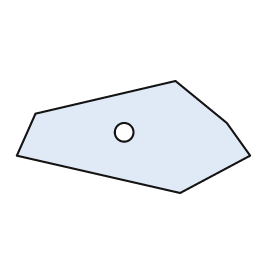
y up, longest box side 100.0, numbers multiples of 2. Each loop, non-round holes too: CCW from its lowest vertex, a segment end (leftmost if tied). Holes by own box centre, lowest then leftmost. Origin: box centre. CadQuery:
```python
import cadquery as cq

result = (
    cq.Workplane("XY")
    .moveTo(20.0, -24.0)
    .lineTo(50.0, -8.0)
    .lineTo(40.0, 6.0)
    .lineTo(18.0, 24.0)
    .lineTo(-42.0, 10.0)
    .lineTo(-50.0, -8.0)
    .close()
    .moveTo(-4.0, 2.0)
    .circle(4.0)
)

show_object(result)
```